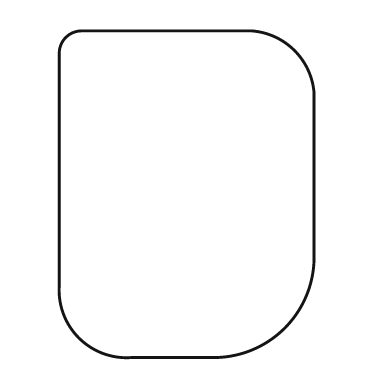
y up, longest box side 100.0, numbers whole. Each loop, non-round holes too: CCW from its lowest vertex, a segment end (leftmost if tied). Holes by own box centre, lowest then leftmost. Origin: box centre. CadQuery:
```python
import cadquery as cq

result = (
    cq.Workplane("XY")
    .moveTo(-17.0, -50.0)
    .lineTo(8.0, -50.0)
    .threePointArc((30.0, -41.0), (39.0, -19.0))
    .lineTo(39.0, 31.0)
    .threePointArc((33.0, 44.0), (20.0, 50.0))
    .lineTo(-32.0, 50.0)
    .threePointArc((-37.0, 48.0), (-39.0, 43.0))
    .lineTo(-39.0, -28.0)
    .threePointArc((-33.0, -44.0), (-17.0, -50.0))
    .close()
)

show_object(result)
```